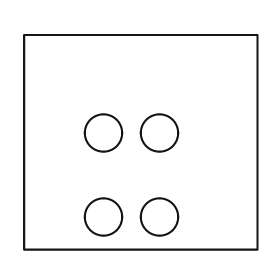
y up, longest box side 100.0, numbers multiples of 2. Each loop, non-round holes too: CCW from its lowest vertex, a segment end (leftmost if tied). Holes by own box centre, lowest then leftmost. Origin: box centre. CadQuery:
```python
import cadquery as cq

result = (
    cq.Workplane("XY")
    .moveTo(-50.0, -46.0)
    .lineTo(50.0, -46.0)
    .lineTo(50.0, 46.0)
    .lineTo(-50.0, 46.0)
    .close()
    .moveTo(-16.0, -32.0)
    .circle(8.0)
    .moveTo(8.0, -32.0)
    .circle(8.0)
    .moveTo(-16.0, 4.0)
    .circle(8.0)
    .moveTo(8.0, 4.0)
    .circle(8.0)
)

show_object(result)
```